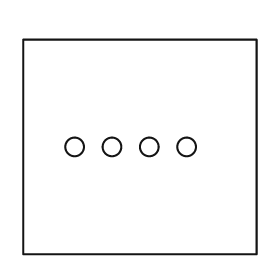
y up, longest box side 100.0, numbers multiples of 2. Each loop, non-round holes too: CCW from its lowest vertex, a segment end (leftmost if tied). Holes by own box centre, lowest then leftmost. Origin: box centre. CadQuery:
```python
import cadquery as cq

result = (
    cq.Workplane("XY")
    .moveTo(-50.0, -46.0)
    .lineTo(50.0, -46.0)
    .lineTo(50.0, 46.0)
    .lineTo(-50.0, 46.0)
    .close()
    .moveTo(-28.0, 0.0)
    .circle(4.0)
    .moveTo(-12.0, 0.0)
    .circle(4.0)
    .moveTo(4.0, 0.0)
    .circle(4.0)
    .moveTo(20.0, 0.0)
    .circle(4.0)
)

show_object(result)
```